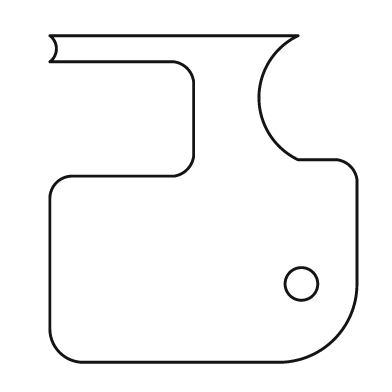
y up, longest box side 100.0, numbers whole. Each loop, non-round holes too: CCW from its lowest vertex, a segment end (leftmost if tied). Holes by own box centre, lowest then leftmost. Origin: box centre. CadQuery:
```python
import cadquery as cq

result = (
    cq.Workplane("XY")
    .moveTo(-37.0, -50.0)
    .lineTo(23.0, -50.0)
    .threePointArc((40.0, -43.0), (47.0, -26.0))
    .lineTo(47.0, 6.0)
    .threePointArc((45.0, 10.0), (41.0, 12.0))
    .lineTo(29.0, 12.0)
    .threePointArc((17.0, 31.0), (29.0, 50.0))
    .lineTo(-47.0, 50.0)
    .threePointArc((-45.0, 46.0), (-47.0, 42.0))
    .lineTo(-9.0, 42.0)
    .threePointArc((-5.0, 40.0), (-3.0, 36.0))
    .lineTo(-3.0, 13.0)
    .threePointArc((-5.0, 9.0), (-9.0, 7.0))
    .lineTo(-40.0, 7.0)
    .threePointArc((-45.0, 5.0), (-47.0, 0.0))
    .lineTo(-47.0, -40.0)
    .threePointArc((-44.0, -47.0), (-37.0, -50.0))
    .close()
    .moveTo(30.0, -26.0)
    .circle(5.0)
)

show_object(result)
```